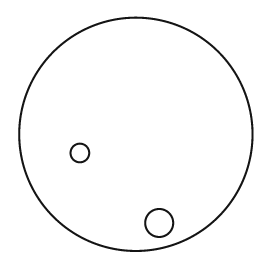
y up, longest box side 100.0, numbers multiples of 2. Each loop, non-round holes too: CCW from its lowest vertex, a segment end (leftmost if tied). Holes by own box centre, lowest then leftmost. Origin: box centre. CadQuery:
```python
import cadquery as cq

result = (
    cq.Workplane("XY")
    .moveTo(0.0, 0.0)
    .circle(50.0)
    .moveTo(10.0, -38.0)
    .circle(6.0)
    .moveTo(-24.0, -8.0)
    .circle(4.0)
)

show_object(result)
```